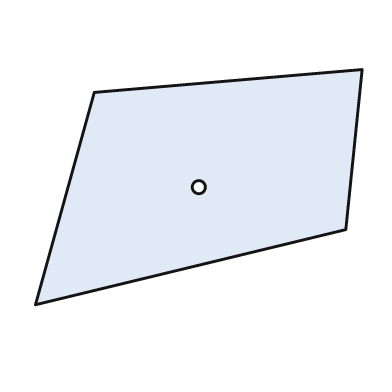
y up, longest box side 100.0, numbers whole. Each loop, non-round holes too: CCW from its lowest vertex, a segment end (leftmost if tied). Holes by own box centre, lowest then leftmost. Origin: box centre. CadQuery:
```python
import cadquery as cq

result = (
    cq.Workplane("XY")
    .moveTo(-50.0, -36.0)
    .lineTo(45.0, -13.0)
    .lineTo(50.0, 36.0)
    .lineTo(-32.0, 29.0)
    .close()
    .moveTo(0.0, 0.0)
    .circle(2.0)
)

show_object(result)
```